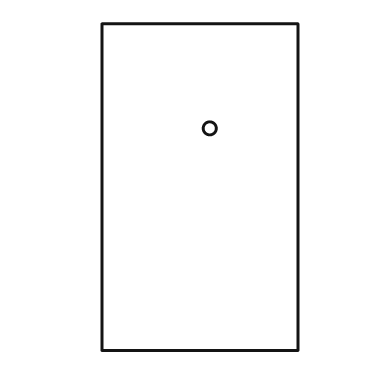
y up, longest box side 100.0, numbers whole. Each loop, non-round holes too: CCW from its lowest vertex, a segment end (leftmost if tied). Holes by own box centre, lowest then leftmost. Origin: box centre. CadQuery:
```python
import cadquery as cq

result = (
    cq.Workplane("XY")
    .moveTo(-30.0, -50.0)
    .lineTo(30.0, -50.0)
    .lineTo(30.0, 50.0)
    .lineTo(-30.0, 50.0)
    .close()
    .moveTo(3.0, 18.0)
    .circle(2.0)
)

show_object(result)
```